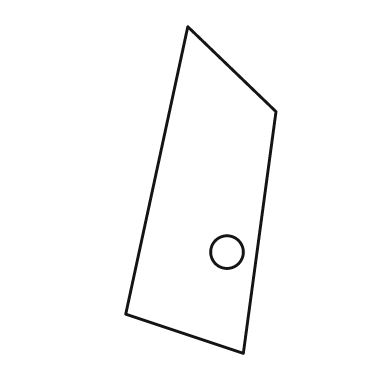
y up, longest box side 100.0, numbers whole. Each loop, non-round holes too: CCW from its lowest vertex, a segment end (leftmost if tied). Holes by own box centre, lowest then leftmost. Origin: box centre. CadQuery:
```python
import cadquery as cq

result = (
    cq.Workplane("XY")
    .moveTo(13.0, -50.0)
    .lineTo(23.0, 24.0)
    .lineTo(-4.0, 50.0)
    .lineTo(-23.0, -38.0)
    .close()
    .moveTo(8.0, -19.0)
    .circle(5.0)
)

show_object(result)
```